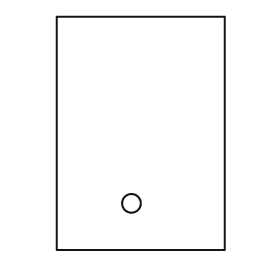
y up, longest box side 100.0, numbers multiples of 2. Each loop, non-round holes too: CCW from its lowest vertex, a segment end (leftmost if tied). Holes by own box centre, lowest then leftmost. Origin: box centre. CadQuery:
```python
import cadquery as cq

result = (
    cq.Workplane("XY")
    .moveTo(-36.0, -50.0)
    .lineTo(36.0, -50.0)
    .lineTo(36.0, 50.0)
    .lineTo(-36.0, 50.0)
    .close()
    .moveTo(-4.0, -30.0)
    .circle(4.0)
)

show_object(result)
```